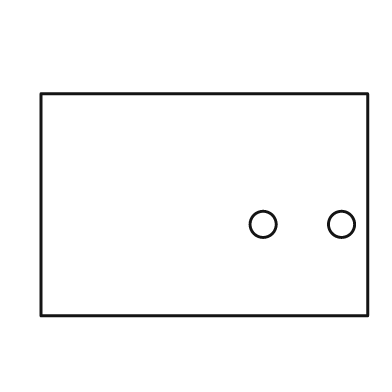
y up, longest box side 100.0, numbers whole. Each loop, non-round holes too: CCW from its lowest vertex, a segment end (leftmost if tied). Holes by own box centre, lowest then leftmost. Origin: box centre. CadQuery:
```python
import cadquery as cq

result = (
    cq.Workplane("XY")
    .moveTo(-50.0, -34.0)
    .lineTo(50.0, -34.0)
    .lineTo(50.0, 34.0)
    .lineTo(-50.0, 34.0)
    .close()
    .moveTo(18.0, -6.0)
    .circle(4.0)
    .moveTo(42.0, -6.0)
    .circle(4.0)
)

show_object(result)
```